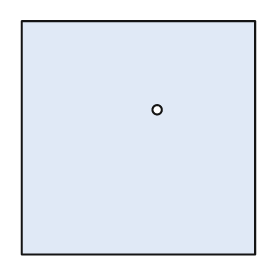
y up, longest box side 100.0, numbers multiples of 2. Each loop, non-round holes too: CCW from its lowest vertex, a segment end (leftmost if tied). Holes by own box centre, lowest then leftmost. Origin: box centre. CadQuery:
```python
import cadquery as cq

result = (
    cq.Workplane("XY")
    .moveTo(-50.0, -50.0)
    .lineTo(50.0, -50.0)
    .lineTo(50.0, 50.0)
    .lineTo(-50.0, 50.0)
    .close()
    .moveTo(8.0, 12.0)
    .circle(2.0)
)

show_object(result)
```